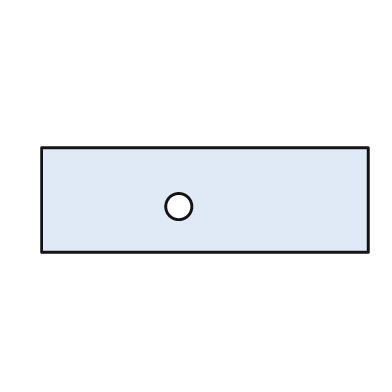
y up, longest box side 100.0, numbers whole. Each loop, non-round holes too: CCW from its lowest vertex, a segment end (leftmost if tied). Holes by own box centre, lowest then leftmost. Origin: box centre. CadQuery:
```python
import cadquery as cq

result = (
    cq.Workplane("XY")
    .moveTo(-50.0, -16.0)
    .lineTo(50.0, -16.0)
    .lineTo(50.0, 16.0)
    .lineTo(-50.0, 16.0)
    .close()
    .moveTo(-8.0, -2.0)
    .circle(4.0)
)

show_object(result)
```